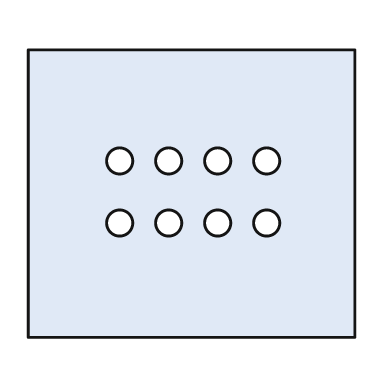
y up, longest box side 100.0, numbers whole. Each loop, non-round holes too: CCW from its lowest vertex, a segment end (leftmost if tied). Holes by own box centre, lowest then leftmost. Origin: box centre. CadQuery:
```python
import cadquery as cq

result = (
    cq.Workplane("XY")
    .moveTo(-50.0, -44.0)
    .lineTo(50.0, -44.0)
    .lineTo(50.0, 44.0)
    .lineTo(-50.0, 44.0)
    .close()
    .moveTo(-22.0, -9.0)
    .circle(4.0)
    .moveTo(-7.0, -9.0)
    .circle(4.0)
    .moveTo(8.0, -9.0)
    .circle(4.0)
    .moveTo(23.0, -9.0)
    .circle(4.0)
    .moveTo(-22.0, 10.0)
    .circle(4.0)
    .moveTo(-7.0, 10.0)
    .circle(4.0)
    .moveTo(8.0, 10.0)
    .circle(4.0)
    .moveTo(23.0, 10.0)
    .circle(4.0)
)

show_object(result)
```